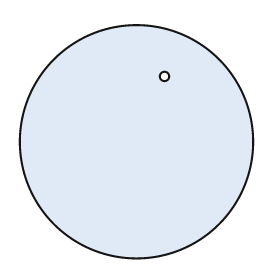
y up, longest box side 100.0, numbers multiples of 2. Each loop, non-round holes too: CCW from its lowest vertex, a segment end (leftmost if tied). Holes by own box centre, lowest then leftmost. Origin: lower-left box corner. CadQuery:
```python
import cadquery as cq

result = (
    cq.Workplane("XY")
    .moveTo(50.0, 50.0)
    .circle(50.0)
    .moveTo(62.0, 78.0)
    .circle(2.0)
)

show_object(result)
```